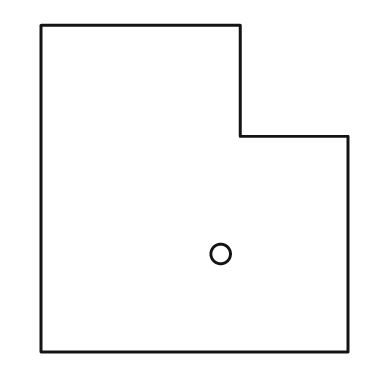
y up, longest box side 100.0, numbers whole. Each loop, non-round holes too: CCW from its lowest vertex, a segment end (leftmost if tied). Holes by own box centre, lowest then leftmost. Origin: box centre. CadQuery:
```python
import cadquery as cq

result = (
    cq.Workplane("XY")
    .moveTo(-47.0, -50.0)
    .lineTo(47.0, -50.0)
    .lineTo(47.0, 16.0)
    .lineTo(14.0, 16.0)
    .lineTo(14.0, 50.0)
    .lineTo(-47.0, 50.0)
    .close()
    .moveTo(8.0, -20.0)
    .circle(3.0)
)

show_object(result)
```